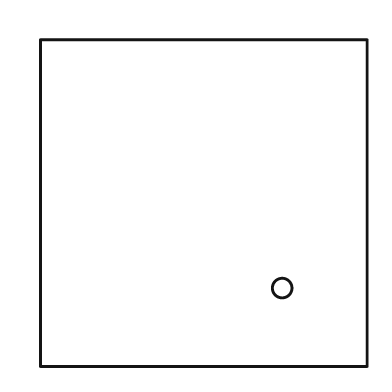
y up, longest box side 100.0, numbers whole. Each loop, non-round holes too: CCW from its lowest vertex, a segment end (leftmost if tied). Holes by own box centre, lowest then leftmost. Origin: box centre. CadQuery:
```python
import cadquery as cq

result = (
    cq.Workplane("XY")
    .moveTo(-50.0, -50.0)
    .lineTo(50.0, -50.0)
    .lineTo(50.0, 50.0)
    .lineTo(-50.0, 50.0)
    .close()
    .moveTo(24.0, -26.0)
    .circle(3.0)
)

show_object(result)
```